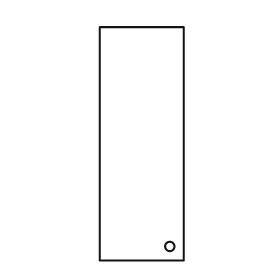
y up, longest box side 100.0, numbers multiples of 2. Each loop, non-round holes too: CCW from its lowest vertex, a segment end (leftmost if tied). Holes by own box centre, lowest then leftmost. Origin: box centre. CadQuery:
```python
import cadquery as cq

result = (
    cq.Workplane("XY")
    .moveTo(-18.0, -50.0)
    .lineTo(18.0, -50.0)
    .lineTo(18.0, 50.0)
    .lineTo(-18.0, 50.0)
    .close()
    .moveTo(12.0, -44.0)
    .circle(2.0)
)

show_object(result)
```